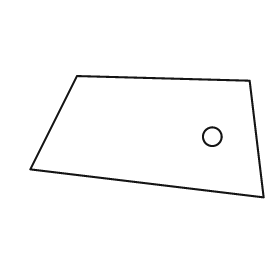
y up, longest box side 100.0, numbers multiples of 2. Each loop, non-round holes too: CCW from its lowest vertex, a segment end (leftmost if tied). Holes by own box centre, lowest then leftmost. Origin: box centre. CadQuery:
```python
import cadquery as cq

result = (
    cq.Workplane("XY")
    .moveTo(50.0, -26.0)
    .lineTo(44.0, 24.0)
    .lineTo(-30.0, 26.0)
    .lineTo(-50.0, -14.0)
    .close()
    .moveTo(28.0, 0.0)
    .circle(4.0)
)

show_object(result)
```